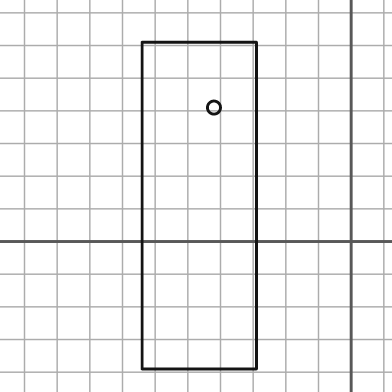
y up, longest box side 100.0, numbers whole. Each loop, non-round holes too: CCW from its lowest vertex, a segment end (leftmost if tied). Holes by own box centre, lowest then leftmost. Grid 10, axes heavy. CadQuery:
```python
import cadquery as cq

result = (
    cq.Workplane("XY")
    .moveTo(-64.0, -39.0)
    .lineTo(-29.0, -39.0)
    .lineTo(-29.0, 61.0)
    .lineTo(-64.0, 61.0)
    .close()
    .moveTo(-42.0, 41.0)
    .circle(2.0)
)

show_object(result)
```